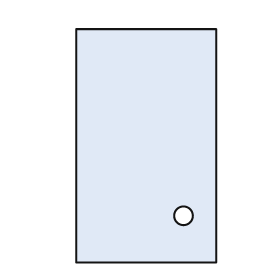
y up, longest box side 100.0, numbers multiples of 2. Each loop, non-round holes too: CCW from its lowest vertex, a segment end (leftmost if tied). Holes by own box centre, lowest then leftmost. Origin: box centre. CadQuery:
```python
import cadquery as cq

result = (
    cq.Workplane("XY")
    .moveTo(-30.0, -50.0)
    .lineTo(30.0, -50.0)
    .lineTo(30.0, 50.0)
    .lineTo(-30.0, 50.0)
    .close()
    .moveTo(16.0, -30.0)
    .circle(4.0)
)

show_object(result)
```